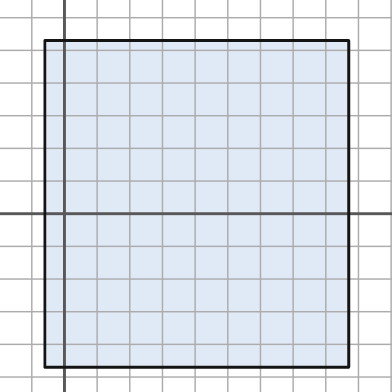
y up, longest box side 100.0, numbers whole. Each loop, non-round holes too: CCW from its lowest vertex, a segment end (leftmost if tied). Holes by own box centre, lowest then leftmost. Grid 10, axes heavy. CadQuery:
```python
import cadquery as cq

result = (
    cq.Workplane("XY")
    .moveTo(-6.0, -47.0)
    .lineTo(87.0, -47.0)
    .lineTo(87.0, 53.0)
    .lineTo(-6.0, 53.0)
    .close()
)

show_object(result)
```